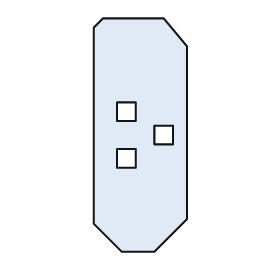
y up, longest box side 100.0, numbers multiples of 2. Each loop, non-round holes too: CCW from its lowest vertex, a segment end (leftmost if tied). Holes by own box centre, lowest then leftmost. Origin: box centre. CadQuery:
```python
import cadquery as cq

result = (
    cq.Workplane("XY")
    .moveTo(-8.0, -50.0)
    .lineTo(6.0, -50.0)
    .lineTo(20.0, -36.0)
    .lineTo(20.0, 38.0)
    .lineTo(10.0, 50.0)
    .lineTo(-16.0, 50.0)
    .lineTo(-20.0, 46.0)
    .lineTo(-20.0, -38.0)
    .close()
    .moveTo(-10.0, -14.0)
    .lineTo(-2.0, -14.0)
    .lineTo(-2.0, -6.0)
    .lineTo(-10.0, -6.0)
    .close()
    .moveTo(6.0, -4.0)
    .lineTo(14.0, -4.0)
    .lineTo(14.0, 4.0)
    .lineTo(6.0, 4.0)
    .close()
    .moveTo(-10.0, 6.0)
    .lineTo(-2.0, 6.0)
    .lineTo(-2.0, 14.0)
    .lineTo(-10.0, 14.0)
    .close()
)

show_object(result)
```